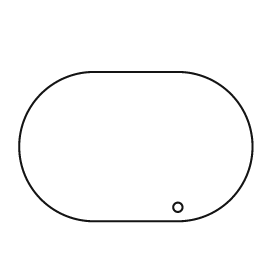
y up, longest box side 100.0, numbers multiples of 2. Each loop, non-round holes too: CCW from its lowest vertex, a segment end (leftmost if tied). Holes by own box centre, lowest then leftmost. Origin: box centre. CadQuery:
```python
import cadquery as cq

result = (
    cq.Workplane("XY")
    .moveTo(-18.0, -32.0)
    .lineTo(18.0, -32.0)
    .threePointArc((50.0, 0.0), (18.0, 32.0))
    .lineTo(-18.0, 32.0)
    .threePointArc((-50.0, 0.0), (-18.0, -32.0))
    .close()
    .moveTo(18.0, -26.0)
    .circle(2.0)
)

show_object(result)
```